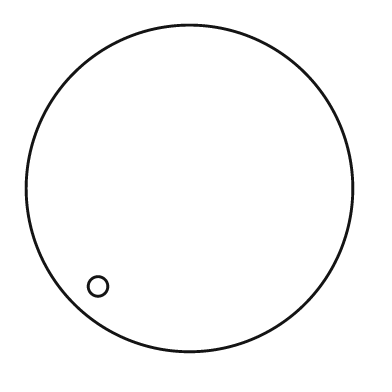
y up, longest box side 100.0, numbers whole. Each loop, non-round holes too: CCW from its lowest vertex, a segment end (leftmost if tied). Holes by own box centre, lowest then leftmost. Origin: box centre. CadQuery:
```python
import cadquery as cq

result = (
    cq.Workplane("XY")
    .moveTo(0.0, 0.0)
    .circle(50.0)
    .moveTo(-28.0, -30.0)
    .circle(3.0)
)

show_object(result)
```